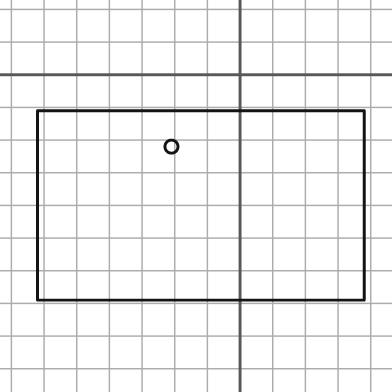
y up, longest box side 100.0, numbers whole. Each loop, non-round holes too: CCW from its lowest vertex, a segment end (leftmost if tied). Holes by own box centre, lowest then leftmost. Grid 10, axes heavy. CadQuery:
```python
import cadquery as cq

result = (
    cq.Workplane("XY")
    .moveTo(-62.0, -69.0)
    .lineTo(38.0, -69.0)
    .lineTo(38.0, -11.0)
    .lineTo(-62.0, -11.0)
    .close()
    .moveTo(-21.0, -22.0)
    .circle(2.0)
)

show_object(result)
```